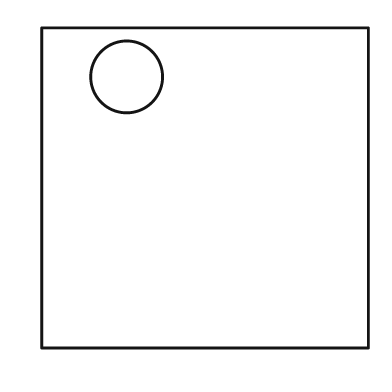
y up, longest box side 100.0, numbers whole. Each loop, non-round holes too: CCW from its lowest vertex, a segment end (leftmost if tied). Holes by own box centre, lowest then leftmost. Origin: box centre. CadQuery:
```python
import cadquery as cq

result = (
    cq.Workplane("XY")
    .moveTo(-50.0, -49.0)
    .lineTo(50.0, -49.0)
    .lineTo(50.0, 49.0)
    .lineTo(-50.0, 49.0)
    .close()
    .moveTo(-24.0, 34.0)
    .circle(11.0)
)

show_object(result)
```